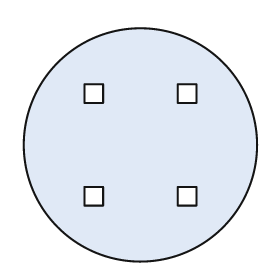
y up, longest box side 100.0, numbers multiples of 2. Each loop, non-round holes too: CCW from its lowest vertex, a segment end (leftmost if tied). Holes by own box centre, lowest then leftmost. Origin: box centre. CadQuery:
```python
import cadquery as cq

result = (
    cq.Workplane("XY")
    .moveTo(0.0, 0.0)
    .circle(50.0)
    .moveTo(-24.0, -26.0)
    .lineTo(-16.0, -26.0)
    .lineTo(-16.0, -18.0)
    .lineTo(-24.0, -18.0)
    .close()
    .moveTo(16.0, -26.0)
    .lineTo(24.0, -26.0)
    .lineTo(24.0, -18.0)
    .lineTo(16.0, -18.0)
    .close()
    .moveTo(-24.0, 18.0)
    .lineTo(-16.0, 18.0)
    .lineTo(-16.0, 26.0)
    .lineTo(-24.0, 26.0)
    .close()
    .moveTo(16.0, 18.0)
    .lineTo(24.0, 18.0)
    .lineTo(24.0, 26.0)
    .lineTo(16.0, 26.0)
    .close()
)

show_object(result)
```